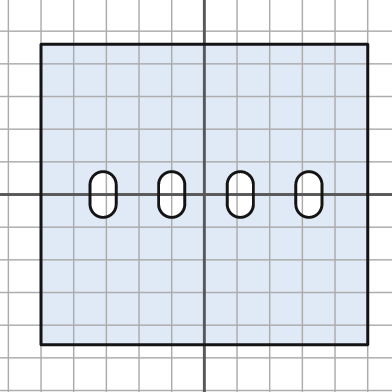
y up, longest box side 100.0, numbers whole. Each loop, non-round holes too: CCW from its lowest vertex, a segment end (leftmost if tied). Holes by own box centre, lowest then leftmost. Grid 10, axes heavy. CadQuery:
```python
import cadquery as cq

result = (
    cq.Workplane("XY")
    .moveTo(-50.0, -46.0)
    .lineTo(50.0, -46.0)
    .lineTo(50.0, 46.0)
    .lineTo(-50.0, 46.0)
    .close()
    .moveTo(-35.0, -3.0)
    .threePointArc((-31.0, -7.0), (-27.0, -3.0))
    .lineTo(-27.0, 3.0)
    .threePointArc((-31.0, 7.0), (-35.0, 3.0))
    .close()
    .moveTo(-14.0, -3.0)
    .threePointArc((-10.0, -7.0), (-6.0, -3.0))
    .lineTo(-6.0, 3.0)
    .threePointArc((-10.0, 7.0), (-14.0, 3.0))
    .close()
    .moveTo(7.0, -3.0)
    .threePointArc((11.0, -7.0), (15.0, -3.0))
    .lineTo(15.0, 3.0)
    .threePointArc((11.0, 7.0), (7.0, 3.0))
    .close()
    .moveTo(28.0, -3.0)
    .threePointArc((32.0, -7.0), (36.0, -3.0))
    .lineTo(36.0, 3.0)
    .threePointArc((32.0, 7.0), (28.0, 3.0))
    .close()
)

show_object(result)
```